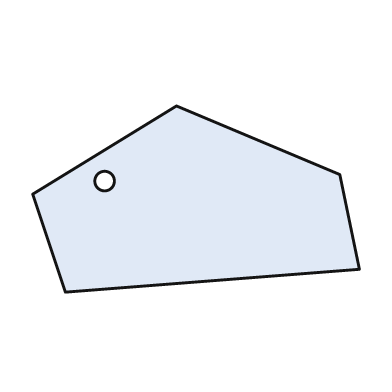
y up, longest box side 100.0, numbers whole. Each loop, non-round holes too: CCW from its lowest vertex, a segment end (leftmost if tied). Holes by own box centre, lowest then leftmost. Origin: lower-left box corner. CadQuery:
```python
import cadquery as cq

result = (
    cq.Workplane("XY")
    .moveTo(10.0, 0.0)
    .lineTo(100.0, 7.0)
    .lineTo(94.0, 36.0)
    .lineTo(44.0, 57.0)
    .lineTo(0.0, 30.0)
    .close()
    .moveTo(22.0, 34.0)
    .circle(3.0)
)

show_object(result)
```